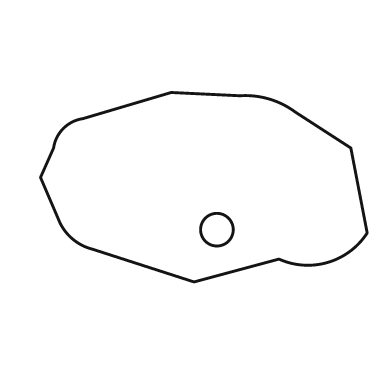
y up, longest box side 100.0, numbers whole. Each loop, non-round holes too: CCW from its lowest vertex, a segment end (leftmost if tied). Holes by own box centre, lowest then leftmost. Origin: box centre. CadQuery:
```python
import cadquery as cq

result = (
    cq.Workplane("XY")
    .moveTo(-3.0, -29.0)
    .lineTo(23.0, -22.0)
    .threePointArc((38.0, -23.0), (50.0, -14.0))
    .lineTo(45.0, 12.0)
    .lineTo(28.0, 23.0)
    .threePointArc((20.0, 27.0), (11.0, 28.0))
    .lineTo(-10.0, 29.0)
    .lineTo(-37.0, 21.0)
    .threePointArc((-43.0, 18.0), (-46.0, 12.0))
    .lineTo(-50.0, 3.0)
    .lineTo(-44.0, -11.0)
    .threePointArc((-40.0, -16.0), (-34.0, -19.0))
    .close()
    .moveTo(4.0, -13.0)
    .circle(5.0)
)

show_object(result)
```